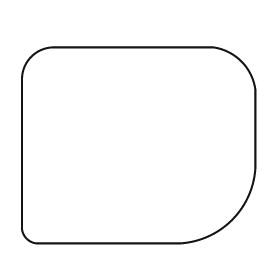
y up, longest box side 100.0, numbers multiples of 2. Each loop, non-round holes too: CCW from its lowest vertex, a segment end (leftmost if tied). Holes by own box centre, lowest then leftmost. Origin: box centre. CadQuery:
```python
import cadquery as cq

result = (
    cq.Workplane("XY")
    .moveTo(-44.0, -42.0)
    .lineTo(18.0, -42.0)
    .threePointArc((40.0, -32.0), (50.0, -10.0))
    .lineTo(50.0, 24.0)
    .threePointArc((44.0, 36.0), (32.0, 42.0))
    .lineTo(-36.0, 42.0)
    .threePointArc((-46.0, 38.0), (-50.0, 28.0))
    .lineTo(-50.0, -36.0)
    .threePointArc((-48.0, -40.0), (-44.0, -42.0))
    .close()
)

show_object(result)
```